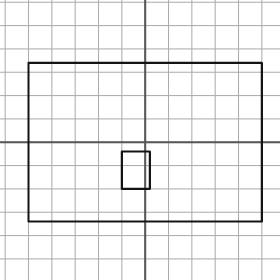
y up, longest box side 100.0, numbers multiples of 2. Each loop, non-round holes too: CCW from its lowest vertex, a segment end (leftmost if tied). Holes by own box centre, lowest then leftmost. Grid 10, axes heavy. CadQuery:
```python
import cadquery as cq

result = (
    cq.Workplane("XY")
    .moveTo(-50.0, -34.0)
    .lineTo(50.0, -34.0)
    .lineTo(50.0, 34.0)
    .lineTo(-50.0, 34.0)
    .close()
    .moveTo(-10.0, -20.0)
    .lineTo(2.0, -20.0)
    .lineTo(2.0, -4.0)
    .lineTo(-10.0, -4.0)
    .close()
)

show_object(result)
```